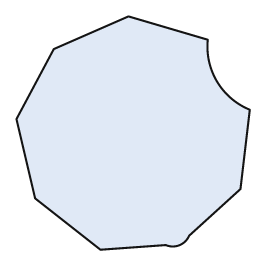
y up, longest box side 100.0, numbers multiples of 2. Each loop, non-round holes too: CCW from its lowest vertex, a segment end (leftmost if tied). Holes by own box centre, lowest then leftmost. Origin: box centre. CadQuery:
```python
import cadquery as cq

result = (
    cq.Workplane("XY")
    .moveTo(-14.0, -50.0)
    .lineTo(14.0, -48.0)
    .threePointArc((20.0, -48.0), (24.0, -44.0))
    .lineTo(46.0, -24.0)
    .lineTo(50.0, 10.0)
    .threePointArc((36.0, 22.0), (32.0, 40.0))
    .lineTo(-2.0, 50.0)
    .lineTo(-34.0, 36.0)
    .lineTo(-50.0, 6.0)
    .lineTo(-42.0, -28.0)
    .close()
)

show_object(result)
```